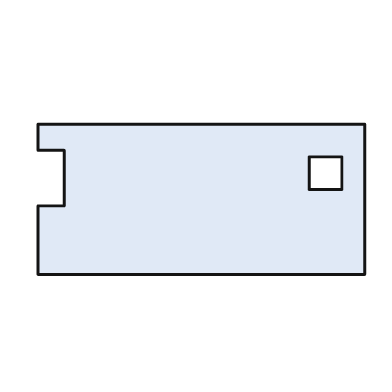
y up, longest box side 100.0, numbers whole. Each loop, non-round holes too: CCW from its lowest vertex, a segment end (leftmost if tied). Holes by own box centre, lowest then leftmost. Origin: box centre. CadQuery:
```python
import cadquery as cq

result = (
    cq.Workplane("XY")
    .moveTo(-50.0, -23.0)
    .lineTo(50.0, -23.0)
    .lineTo(50.0, 23.0)
    .lineTo(-50.0, 23.0)
    .lineTo(-50.0, 15.0)
    .lineTo(-42.0, 15.0)
    .lineTo(-42.0, -2.0)
    .lineTo(-50.0, -2.0)
    .close()
    .moveTo(33.0, 3.0)
    .lineTo(43.0, 3.0)
    .lineTo(43.0, 13.0)
    .lineTo(33.0, 13.0)
    .close()
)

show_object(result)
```